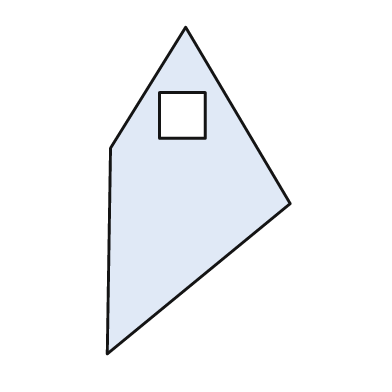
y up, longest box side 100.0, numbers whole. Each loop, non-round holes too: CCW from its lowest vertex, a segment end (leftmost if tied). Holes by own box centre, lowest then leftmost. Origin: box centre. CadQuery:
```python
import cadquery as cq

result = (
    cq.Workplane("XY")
    .moveTo(-28.0, -50.0)
    .lineTo(28.0, -4.0)
    .lineTo(-4.0, 50.0)
    .lineTo(-27.0, 13.0)
    .close()
    .moveTo(-12.0, 16.0)
    .lineTo(2.0, 16.0)
    .lineTo(2.0, 30.0)
    .lineTo(-12.0, 30.0)
    .close()
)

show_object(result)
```